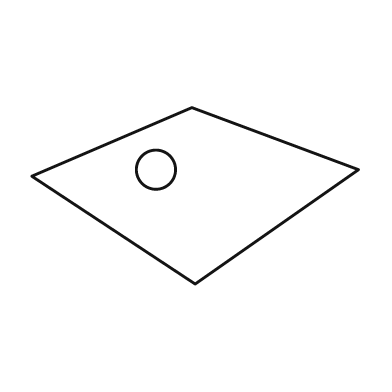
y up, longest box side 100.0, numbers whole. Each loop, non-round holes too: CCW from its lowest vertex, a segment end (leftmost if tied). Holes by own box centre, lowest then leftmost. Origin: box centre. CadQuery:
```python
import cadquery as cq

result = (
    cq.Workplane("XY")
    .moveTo(0.0, -27.0)
    .lineTo(50.0, 8.0)
    .lineTo(-1.0, 27.0)
    .lineTo(-50.0, 6.0)
    .close()
    .moveTo(-12.0, 8.0)
    .circle(6.0)
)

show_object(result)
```